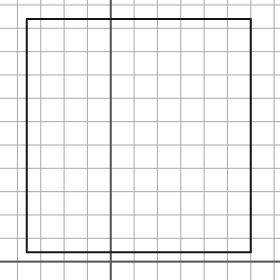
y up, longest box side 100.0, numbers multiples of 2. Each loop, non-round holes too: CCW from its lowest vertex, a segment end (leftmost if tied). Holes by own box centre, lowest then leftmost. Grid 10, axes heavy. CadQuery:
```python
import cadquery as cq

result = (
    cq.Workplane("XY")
    .moveTo(-36.0, 4.0)
    .lineTo(60.0, 4.0)
    .lineTo(60.0, 104.0)
    .lineTo(-36.0, 104.0)
    .close()
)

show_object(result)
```